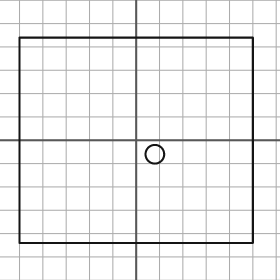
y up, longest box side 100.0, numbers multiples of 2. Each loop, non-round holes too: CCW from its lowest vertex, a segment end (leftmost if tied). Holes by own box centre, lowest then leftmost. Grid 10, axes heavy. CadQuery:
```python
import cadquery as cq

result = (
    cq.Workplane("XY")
    .moveTo(-50.0, -44.0)
    .lineTo(50.0, -44.0)
    .lineTo(50.0, 44.0)
    .lineTo(-50.0, 44.0)
    .close()
    .moveTo(8.0, -6.0)
    .circle(4.0)
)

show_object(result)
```